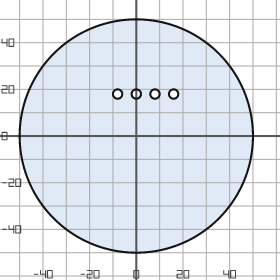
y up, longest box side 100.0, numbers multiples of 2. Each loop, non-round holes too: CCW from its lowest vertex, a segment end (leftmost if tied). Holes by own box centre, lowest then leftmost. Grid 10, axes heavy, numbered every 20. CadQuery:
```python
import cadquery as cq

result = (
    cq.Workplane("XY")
    .moveTo(0.0, 0.0)
    .circle(50.0)
    .moveTo(-8.0, 18.0)
    .circle(2.0)
    .moveTo(0.0, 18.0)
    .circle(2.0)
    .moveTo(8.0, 18.0)
    .circle(2.0)
    .moveTo(16.0, 18.0)
    .circle(2.0)
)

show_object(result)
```